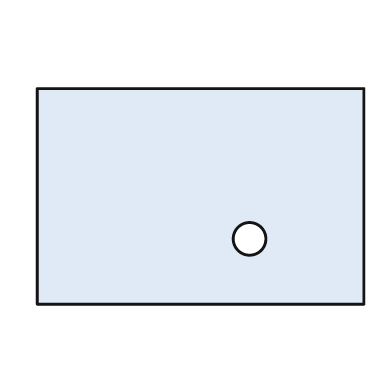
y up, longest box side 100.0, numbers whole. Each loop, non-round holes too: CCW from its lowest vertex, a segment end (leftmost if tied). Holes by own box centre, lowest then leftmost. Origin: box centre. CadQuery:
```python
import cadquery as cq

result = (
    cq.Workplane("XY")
    .moveTo(-50.0, -33.0)
    .lineTo(50.0, -33.0)
    .lineTo(50.0, 33.0)
    .lineTo(-50.0, 33.0)
    .close()
    .moveTo(15.0, -13.0)
    .circle(5.0)
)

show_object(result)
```